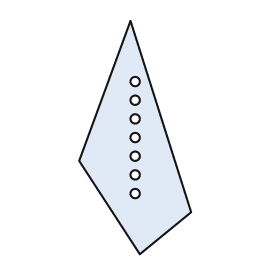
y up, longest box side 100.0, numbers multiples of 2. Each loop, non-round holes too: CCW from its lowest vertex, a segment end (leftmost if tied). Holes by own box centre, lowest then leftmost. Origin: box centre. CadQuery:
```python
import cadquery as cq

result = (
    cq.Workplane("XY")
    .moveTo(2.0, -50.0)
    .lineTo(24.0, -32.0)
    .lineTo(-2.0, 50.0)
    .lineTo(-24.0, -10.0)
    .close()
    .moveTo(0.0, -24.0)
    .circle(2.0)
    .moveTo(0.0, -16.0)
    .circle(2.0)
    .moveTo(0.0, -8.0)
    .circle(2.0)
    .moveTo(0.0, 0.0)
    .circle(2.0)
    .moveTo(0.0, 8.0)
    .circle(2.0)
    .moveTo(0.0, 16.0)
    .circle(2.0)
    .moveTo(0.0, 24.0)
    .circle(2.0)
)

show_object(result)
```